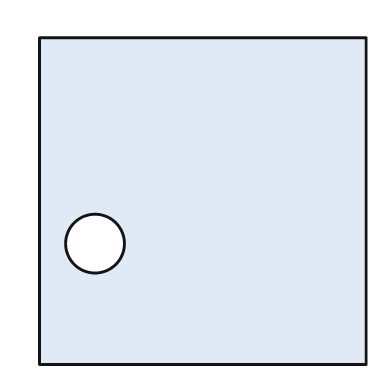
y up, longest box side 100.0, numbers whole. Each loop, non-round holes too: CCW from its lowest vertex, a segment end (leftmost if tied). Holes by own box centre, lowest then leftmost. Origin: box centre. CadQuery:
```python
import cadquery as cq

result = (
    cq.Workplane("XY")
    .moveTo(-50.0, -50.0)
    .lineTo(50.0, -50.0)
    .lineTo(50.0, 50.0)
    .lineTo(-50.0, 50.0)
    .close()
    .moveTo(-33.0, -13.0)
    .circle(9.0)
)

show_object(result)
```